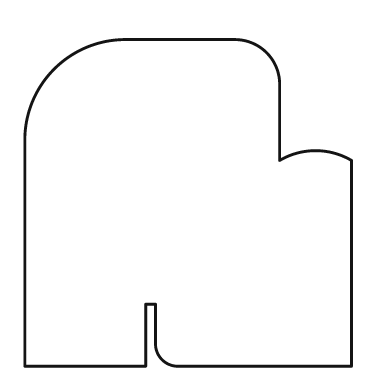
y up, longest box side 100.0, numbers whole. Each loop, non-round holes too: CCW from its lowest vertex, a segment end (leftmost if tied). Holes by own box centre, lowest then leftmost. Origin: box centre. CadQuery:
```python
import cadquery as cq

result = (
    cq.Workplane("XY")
    .moveTo(-50.0, -50.0)
    .lineTo(-13.0, -50.0)
    .lineTo(-13.0, -31.0)
    .lineTo(-10.0, -31.0)
    .lineTo(-10.0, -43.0)
    .threePointArc((-8.0, -48.0), (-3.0, -50.0))
    .lineTo(50.0, -50.0)
    .lineTo(50.0, 13.0)
    .threePointArc((39.0, 16.0), (28.0, 13.0))
    .lineTo(28.0, 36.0)
    .threePointArc((24.0, 46.0), (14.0, 50.0))
    .lineTo(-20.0, 50.0)
    .threePointArc((-41.0, 41.0), (-50.0, 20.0))
    .close()
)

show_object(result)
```